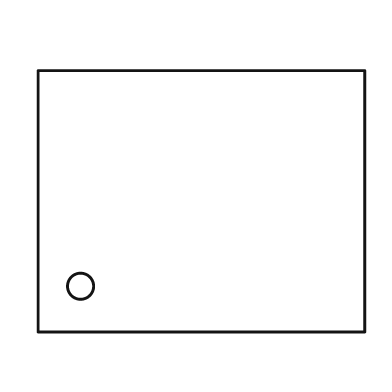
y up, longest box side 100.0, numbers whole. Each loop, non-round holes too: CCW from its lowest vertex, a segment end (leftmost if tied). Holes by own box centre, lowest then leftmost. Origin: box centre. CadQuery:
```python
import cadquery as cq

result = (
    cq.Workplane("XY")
    .moveTo(-50.0, -40.0)
    .lineTo(50.0, -40.0)
    .lineTo(50.0, 40.0)
    .lineTo(-50.0, 40.0)
    .close()
    .moveTo(-37.0, -26.0)
    .circle(4.0)
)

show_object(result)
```